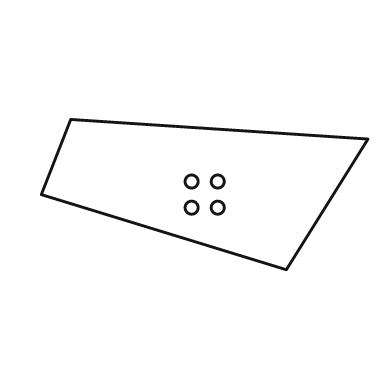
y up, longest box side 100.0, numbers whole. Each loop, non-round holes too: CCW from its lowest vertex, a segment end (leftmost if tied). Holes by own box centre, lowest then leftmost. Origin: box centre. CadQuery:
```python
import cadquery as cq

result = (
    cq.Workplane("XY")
    .moveTo(25.0, -23.0)
    .lineTo(50.0, 17.0)
    .lineTo(-41.0, 23.0)
    .lineTo(-50.0, 0.0)
    .close()
    .moveTo(-4.0, -4.0)
    .circle(2.0)
    .moveTo(4.0, -4.0)
    .circle(2.0)
    .moveTo(-4.0, 4.0)
    .circle(2.0)
    .moveTo(4.0, 4.0)
    .circle(2.0)
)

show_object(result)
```